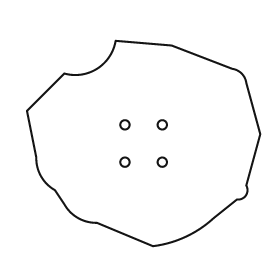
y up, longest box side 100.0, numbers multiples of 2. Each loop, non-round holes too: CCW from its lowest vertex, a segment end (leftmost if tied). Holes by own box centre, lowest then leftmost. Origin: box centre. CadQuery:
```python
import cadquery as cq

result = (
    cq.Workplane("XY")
    .moveTo(4.0, -44.0)
    .threePointArc((18.0, -40.0), (30.0, -32.0))
    .lineTo(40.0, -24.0)
    .threePointArc((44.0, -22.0), (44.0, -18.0))
    .lineTo(50.0, 4.0)
    .lineTo(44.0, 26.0)
    .threePointArc((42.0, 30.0), (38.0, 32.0))
    .lineTo(12.0, 42.0)
    .lineTo(-12.0, 44.0)
    .threePointArc((-20.0, 32.0), (-34.0, 30.0))
    .lineTo(-50.0, 14.0)
    .lineTo(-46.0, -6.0)
    .threePointArc((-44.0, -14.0), (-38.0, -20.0))
    .lineTo(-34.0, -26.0)
    .threePointArc((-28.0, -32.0), (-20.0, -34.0))
    .close()
    .moveTo(-8.0, -8.0)
    .circle(2.0)
    .moveTo(8.0, -8.0)
    .circle(2.0)
    .moveTo(-8.0, 8.0)
    .circle(2.0)
    .moveTo(8.0, 8.0)
    .circle(2.0)
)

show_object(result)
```